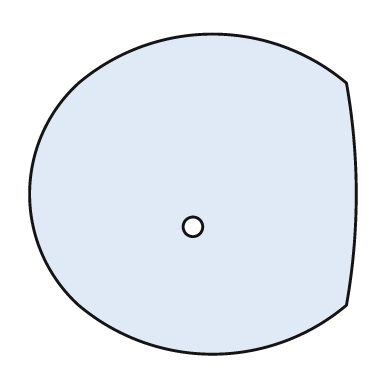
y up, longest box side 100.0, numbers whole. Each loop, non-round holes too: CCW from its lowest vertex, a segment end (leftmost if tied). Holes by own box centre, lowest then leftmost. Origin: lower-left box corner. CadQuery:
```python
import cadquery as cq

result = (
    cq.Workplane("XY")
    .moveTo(15.0, 15.0)
    .threePointArc((56.0, 0.0), (97.0, 15.0))
    .threePointArc((100.0, 49.0), (97.0, 83.0))
    .threePointArc((56.0, 98.0), (15.0, 83.0))
    .threePointArc((0.0, 49.0), (15.0, 15.0))
    .close()
    .moveTo(50.0, 39.0)
    .circle(3.0)
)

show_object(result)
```